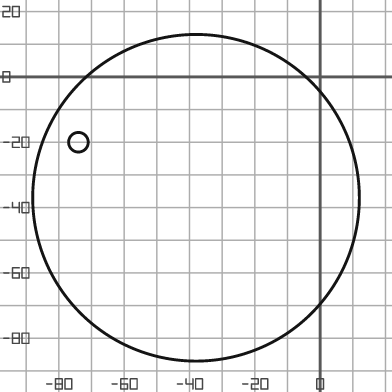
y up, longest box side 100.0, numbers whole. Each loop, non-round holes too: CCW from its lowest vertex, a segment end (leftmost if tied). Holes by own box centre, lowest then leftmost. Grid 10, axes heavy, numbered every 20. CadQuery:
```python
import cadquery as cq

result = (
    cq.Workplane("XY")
    .moveTo(-38.0, -37.0)
    .circle(50.0)
    .moveTo(-74.0, -20.0)
    .circle(3.0)
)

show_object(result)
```